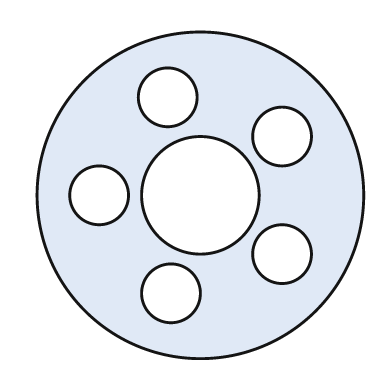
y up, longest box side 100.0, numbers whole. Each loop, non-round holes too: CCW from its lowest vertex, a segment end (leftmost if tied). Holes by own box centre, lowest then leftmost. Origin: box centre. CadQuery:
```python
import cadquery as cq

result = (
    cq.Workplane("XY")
    .moveTo(0.0, 0.0)
    .circle(50.0)
    .moveTo(-9.0, -30.0)
    .circle(9.0)
    .moveTo(25.0, -18.0)
    .circle(9.0)
    .moveTo(-31.0, 0.0)
    .circle(9.0)
    .moveTo(0.0, 0.0)
    .circle(18.0)
    .moveTo(25.0, 18.0)
    .circle(9.0)
    .moveTo(-10.0, 30.0)
    .circle(9.0)
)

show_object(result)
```